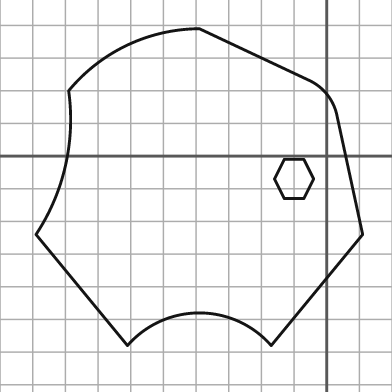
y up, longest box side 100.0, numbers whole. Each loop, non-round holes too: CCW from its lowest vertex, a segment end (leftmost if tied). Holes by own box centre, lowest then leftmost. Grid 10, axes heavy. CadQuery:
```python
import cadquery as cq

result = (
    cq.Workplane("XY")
    .moveTo(-61.0, -58.0)
    .threePointArc((-39.0, -48.0), (-17.0, -58.0))
    .lineTo(11.0, -24.0)
    .lineTo(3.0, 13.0)
    .threePointArc((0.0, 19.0), (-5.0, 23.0))
    .lineTo(-39.0, 39.0)
    .threePointArc((-61.0, 34.0), (-79.0, 20.0))
    .threePointArc((-80.0, -3.0), (-89.0, -24.0))
    .close()
    .moveTo(-13.0, -13.0)
    .lineTo(-7.0, -13.0)
    .lineTo(-4.0, -7.0)
    .lineTo(-7.0, -1.0)
    .lineTo(-13.0, -1.0)
    .lineTo(-16.0, -7.0)
    .close()
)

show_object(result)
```